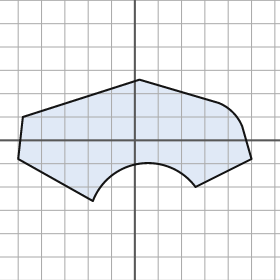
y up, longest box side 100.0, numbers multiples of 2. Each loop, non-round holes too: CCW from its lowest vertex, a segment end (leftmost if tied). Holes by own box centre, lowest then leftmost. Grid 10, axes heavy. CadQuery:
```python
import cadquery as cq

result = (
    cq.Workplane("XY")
    .moveTo(-18.0, -26.0)
    .threePointArc((2.0, -10.0), (26.0, -20.0))
    .lineTo(50.0, -8.0)
    .lineTo(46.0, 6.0)
    .threePointArc((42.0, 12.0), (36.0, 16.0))
    .lineTo(2.0, 26.0)
    .lineTo(-48.0, 10.0)
    .lineTo(-50.0, -8.0)
    .close()
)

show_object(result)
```